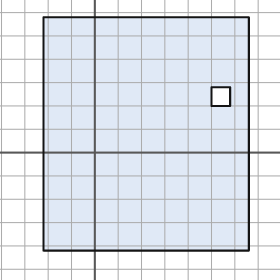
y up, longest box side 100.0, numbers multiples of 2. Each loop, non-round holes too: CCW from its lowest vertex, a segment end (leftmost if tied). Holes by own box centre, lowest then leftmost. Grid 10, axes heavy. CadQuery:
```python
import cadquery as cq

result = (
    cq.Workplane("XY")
    .moveTo(-22.0, -42.0)
    .lineTo(66.0, -42.0)
    .lineTo(66.0, 58.0)
    .lineTo(-22.0, 58.0)
    .close()
    .moveTo(50.0, 20.0)
    .lineTo(58.0, 20.0)
    .lineTo(58.0, 28.0)
    .lineTo(50.0, 28.0)
    .close()
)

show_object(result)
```